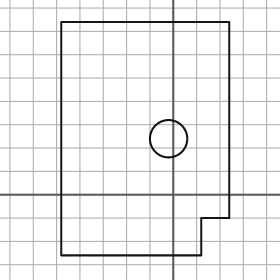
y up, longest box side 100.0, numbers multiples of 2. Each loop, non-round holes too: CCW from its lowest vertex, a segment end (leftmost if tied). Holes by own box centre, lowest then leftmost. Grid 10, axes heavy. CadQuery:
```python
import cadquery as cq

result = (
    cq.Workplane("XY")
    .moveTo(-48.0, -26.0)
    .lineTo(12.0, -26.0)
    .lineTo(12.0, -10.0)
    .lineTo(24.0, -10.0)
    .lineTo(24.0, 74.0)
    .lineTo(-48.0, 74.0)
    .close()
    .moveTo(-2.0, 24.0)
    .circle(8.0)
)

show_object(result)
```